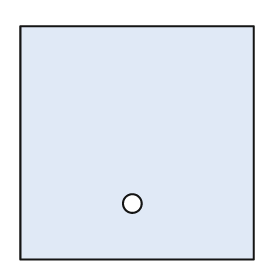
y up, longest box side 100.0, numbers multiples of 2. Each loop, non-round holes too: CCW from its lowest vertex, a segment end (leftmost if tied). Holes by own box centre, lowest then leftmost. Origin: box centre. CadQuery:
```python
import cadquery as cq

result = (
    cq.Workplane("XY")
    .moveTo(-50.0, -50.0)
    .lineTo(50.0, -50.0)
    .lineTo(50.0, 50.0)
    .lineTo(-50.0, 50.0)
    .close()
    .moveTo(-2.0, -26.0)
    .circle(4.0)
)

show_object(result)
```